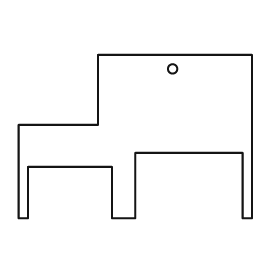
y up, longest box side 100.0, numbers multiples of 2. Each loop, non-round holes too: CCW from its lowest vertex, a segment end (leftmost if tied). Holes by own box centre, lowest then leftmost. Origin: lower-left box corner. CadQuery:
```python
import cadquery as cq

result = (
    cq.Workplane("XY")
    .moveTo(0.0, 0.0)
    .lineTo(4.0, 0.0)
    .lineTo(4.0, 22.0)
    .lineTo(40.0, 22.0)
    .lineTo(40.0, 0.0)
    .lineTo(50.0, 0.0)
    .lineTo(50.0, 28.0)
    .lineTo(96.0, 28.0)
    .lineTo(96.0, 0.0)
    .lineTo(100.0, 0.0)
    .lineTo(100.0, 70.0)
    .lineTo(34.0, 70.0)
    .lineTo(34.0, 40.0)
    .lineTo(0.0, 40.0)
    .close()
    .moveTo(66.0, 64.0)
    .circle(2.0)
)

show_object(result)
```